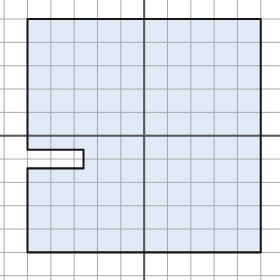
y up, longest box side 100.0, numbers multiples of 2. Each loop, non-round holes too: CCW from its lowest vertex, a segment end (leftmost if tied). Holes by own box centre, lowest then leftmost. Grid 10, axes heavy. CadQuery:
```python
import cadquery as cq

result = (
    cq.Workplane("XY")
    .moveTo(-50.0, -50.0)
    .lineTo(50.0, -50.0)
    .lineTo(50.0, 50.0)
    .lineTo(-50.0, 50.0)
    .lineTo(-50.0, -6.0)
    .lineTo(-26.0, -6.0)
    .lineTo(-26.0, -14.0)
    .lineTo(-50.0, -14.0)
    .close()
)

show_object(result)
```